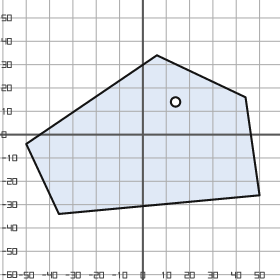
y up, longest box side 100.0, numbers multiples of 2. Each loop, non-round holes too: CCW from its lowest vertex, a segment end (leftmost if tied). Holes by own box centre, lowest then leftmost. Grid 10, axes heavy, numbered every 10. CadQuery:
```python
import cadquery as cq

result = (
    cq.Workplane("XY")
    .moveTo(-36.0, -34.0)
    .lineTo(50.0, -26.0)
    .lineTo(44.0, 16.0)
    .lineTo(6.0, 34.0)
    .lineTo(-50.0, -4.0)
    .close()
    .moveTo(14.0, 14.0)
    .circle(2.0)
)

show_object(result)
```